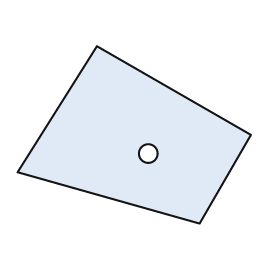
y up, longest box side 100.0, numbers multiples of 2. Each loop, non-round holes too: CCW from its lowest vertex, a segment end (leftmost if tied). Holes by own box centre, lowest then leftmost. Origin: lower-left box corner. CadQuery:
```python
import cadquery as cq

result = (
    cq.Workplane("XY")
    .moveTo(78.0, 0.0)
    .lineTo(100.0, 38.0)
    .lineTo(34.0, 76.0)
    .lineTo(0.0, 22.0)
    .close()
    .moveTo(56.0, 30.0)
    .circle(4.0)
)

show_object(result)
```